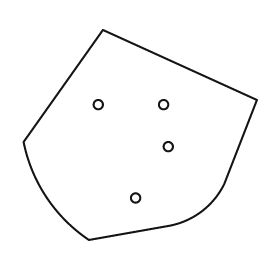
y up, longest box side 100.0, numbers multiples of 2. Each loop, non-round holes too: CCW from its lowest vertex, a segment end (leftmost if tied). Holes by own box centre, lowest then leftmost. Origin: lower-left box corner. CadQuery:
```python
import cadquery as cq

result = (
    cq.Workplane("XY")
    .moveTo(28.0, 0.0)
    .lineTo(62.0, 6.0)
    .threePointArc((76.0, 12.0), (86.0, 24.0))
    .lineTo(100.0, 60.0)
    .lineTo(34.0, 90.0)
    .lineTo(0.0, 42.0)
    .threePointArc((10.0, 18.0), (28.0, 0.0))
    .close()
    .moveTo(48.0, 18.0)
    .circle(2.0)
    .moveTo(62.0, 40.0)
    .circle(2.0)
    .moveTo(32.0, 58.0)
    .circle(2.0)
    .moveTo(60.0, 58.0)
    .circle(2.0)
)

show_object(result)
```